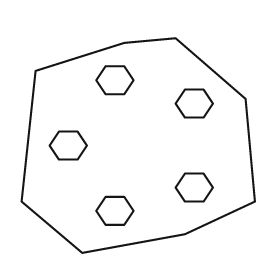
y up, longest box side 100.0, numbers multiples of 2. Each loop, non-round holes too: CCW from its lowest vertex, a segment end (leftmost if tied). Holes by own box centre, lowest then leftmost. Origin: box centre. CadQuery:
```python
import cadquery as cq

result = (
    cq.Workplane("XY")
    .moveTo(-24.0, -46.0)
    .lineTo(20.0, -38.0)
    .lineTo(50.0, -24.0)
    .lineTo(46.0, 20.0)
    .lineTo(16.0, 46.0)
    .lineTo(-6.0, 44.0)
    .lineTo(-44.0, 32.0)
    .lineTo(-50.0, -24.0)
    .close()
    .moveTo(-14.0, -34.0)
    .lineTo(-6.0, -34.0)
    .lineTo(-2.0, -28.0)
    .lineTo(-6.0, -22.0)
    .lineTo(-14.0, -22.0)
    .lineTo(-18.0, -28.0)
    .close()
    .moveTo(20.0, -24.0)
    .lineTo(28.0, -24.0)
    .lineTo(32.0, -18.0)
    .lineTo(28.0, -12.0)
    .lineTo(20.0, -12.0)
    .lineTo(16.0, -18.0)
    .close()
    .moveTo(-34.0, -6.0)
    .lineTo(-26.0, -6.0)
    .lineTo(-22.0, 0.0)
    .lineTo(-26.0, 6.0)
    .lineTo(-34.0, 6.0)
    .lineTo(-38.0, 0.0)
    .close()
    .moveTo(20.0, 12.0)
    .lineTo(28.0, 12.0)
    .lineTo(32.0, 18.0)
    .lineTo(28.0, 24.0)
    .lineTo(20.0, 24.0)
    .lineTo(16.0, 18.0)
    .close()
    .moveTo(-14.0, 22.0)
    .lineTo(-6.0, 22.0)
    .lineTo(-2.0, 28.0)
    .lineTo(-6.0, 34.0)
    .lineTo(-14.0, 34.0)
    .lineTo(-18.0, 28.0)
    .close()
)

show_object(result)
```